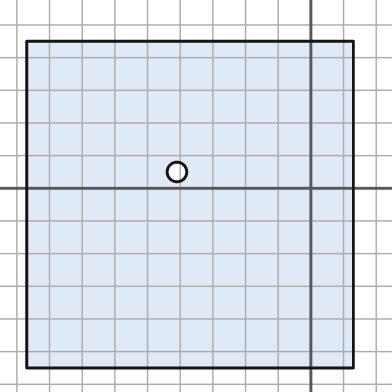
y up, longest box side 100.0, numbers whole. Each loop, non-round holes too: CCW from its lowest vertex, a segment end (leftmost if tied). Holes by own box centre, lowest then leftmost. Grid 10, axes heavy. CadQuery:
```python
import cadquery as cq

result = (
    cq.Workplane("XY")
    .moveTo(-87.0, -55.0)
    .lineTo(13.0, -55.0)
    .lineTo(13.0, 45.0)
    .lineTo(-87.0, 45.0)
    .close()
    .moveTo(-41.0, 5.0)
    .circle(3.0)
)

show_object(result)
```